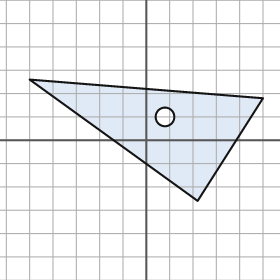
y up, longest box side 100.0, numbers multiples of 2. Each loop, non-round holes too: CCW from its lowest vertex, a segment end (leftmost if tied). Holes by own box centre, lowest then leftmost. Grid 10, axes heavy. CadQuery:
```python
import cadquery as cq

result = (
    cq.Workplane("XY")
    .moveTo(22.0, -26.0)
    .lineTo(50.0, 18.0)
    .lineTo(-50.0, 26.0)
    .close()
    .moveTo(8.0, 10.0)
    .circle(4.0)
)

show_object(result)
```